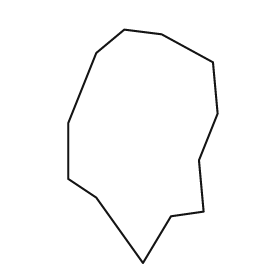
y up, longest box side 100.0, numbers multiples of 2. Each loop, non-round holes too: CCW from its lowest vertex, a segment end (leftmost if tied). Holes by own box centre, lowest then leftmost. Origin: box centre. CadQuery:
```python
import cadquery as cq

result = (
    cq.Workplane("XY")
    .moveTo(0.0, -50.0)
    .lineTo(12.0, -30.0)
    .lineTo(26.0, -28.0)
    .lineTo(24.0, -6.0)
    .lineTo(32.0, 14.0)
    .lineTo(30.0, 36.0)
    .lineTo(8.0, 48.0)
    .lineTo(-8.0, 50.0)
    .lineTo(-20.0, 40.0)
    .lineTo(-32.0, 10.0)
    .lineTo(-32.0, -14.0)
    .lineTo(-20.0, -22.0)
    .close()
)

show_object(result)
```